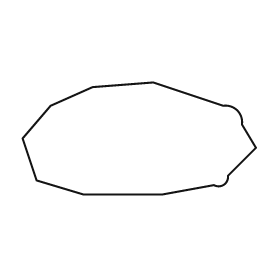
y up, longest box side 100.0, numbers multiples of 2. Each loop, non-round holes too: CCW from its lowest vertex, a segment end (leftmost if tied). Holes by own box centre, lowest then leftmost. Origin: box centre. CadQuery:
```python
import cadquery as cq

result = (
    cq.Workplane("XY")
    .moveTo(-24.0, -24.0)
    .lineTo(10.0, -24.0)
    .lineTo(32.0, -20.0)
    .threePointArc((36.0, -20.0), (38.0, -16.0))
    .lineTo(50.0, -4.0)
    .lineTo(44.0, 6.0)
    .threePointArc((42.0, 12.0), (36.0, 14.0))
    .lineTo(6.0, 24.0)
    .lineTo(-20.0, 22.0)
    .lineTo(-38.0, 14.0)
    .lineTo(-50.0, 0.0)
    .lineTo(-44.0, -18.0)
    .close()
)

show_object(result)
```